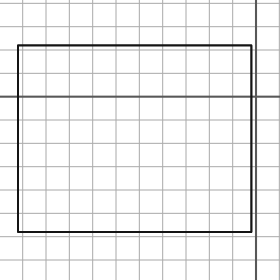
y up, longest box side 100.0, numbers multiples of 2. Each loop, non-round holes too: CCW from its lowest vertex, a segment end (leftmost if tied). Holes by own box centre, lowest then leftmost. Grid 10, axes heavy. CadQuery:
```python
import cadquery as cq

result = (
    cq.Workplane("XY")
    .moveTo(-102.0, -58.0)
    .lineTo(-2.0, -58.0)
    .lineTo(-2.0, 22.0)
    .lineTo(-102.0, 22.0)
    .close()
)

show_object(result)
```